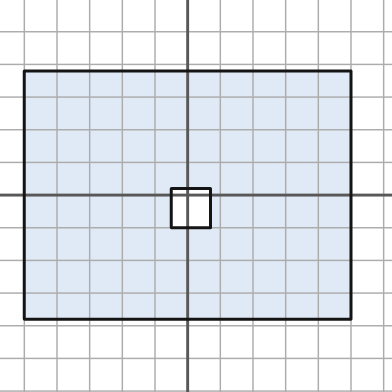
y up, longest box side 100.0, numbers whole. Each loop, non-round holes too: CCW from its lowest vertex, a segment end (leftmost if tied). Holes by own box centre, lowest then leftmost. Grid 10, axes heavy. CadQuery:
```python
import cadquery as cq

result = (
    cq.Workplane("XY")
    .moveTo(-50.0, -38.0)
    .lineTo(50.0, -38.0)
    .lineTo(50.0, 38.0)
    .lineTo(-50.0, 38.0)
    .close()
    .moveTo(-5.0, -10.0)
    .lineTo(7.0, -10.0)
    .lineTo(7.0, 2.0)
    .lineTo(-5.0, 2.0)
    .close()
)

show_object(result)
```